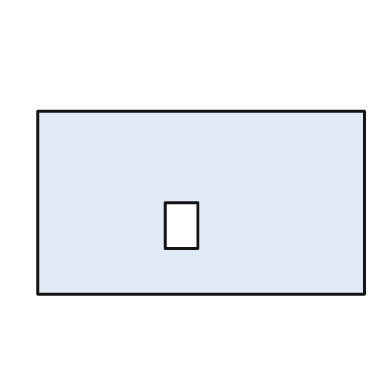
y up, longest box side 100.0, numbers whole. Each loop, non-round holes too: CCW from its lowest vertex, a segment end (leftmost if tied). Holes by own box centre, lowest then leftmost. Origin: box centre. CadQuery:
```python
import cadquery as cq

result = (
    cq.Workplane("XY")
    .moveTo(-50.0, -28.0)
    .lineTo(50.0, -28.0)
    .lineTo(50.0, 28.0)
    .lineTo(-50.0, 28.0)
    .close()
    .moveTo(-11.0, -14.0)
    .lineTo(-1.0, -14.0)
    .lineTo(-1.0, 0.0)
    .lineTo(-11.0, 0.0)
    .close()
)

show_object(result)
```